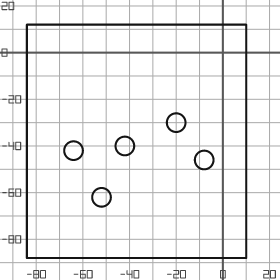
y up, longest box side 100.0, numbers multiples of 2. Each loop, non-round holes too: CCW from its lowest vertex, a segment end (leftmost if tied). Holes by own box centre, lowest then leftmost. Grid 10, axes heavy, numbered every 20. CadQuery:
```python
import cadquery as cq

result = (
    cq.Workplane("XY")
    .moveTo(-84.0, -88.0)
    .lineTo(10.0, -88.0)
    .lineTo(10.0, 12.0)
    .lineTo(-84.0, 12.0)
    .close()
    .moveTo(-52.0, -62.0)
    .circle(4.0)
    .moveTo(-8.0, -46.0)
    .circle(4.0)
    .moveTo(-64.0, -42.0)
    .circle(4.0)
    .moveTo(-42.0, -40.0)
    .circle(4.0)
    .moveTo(-20.0, -30.0)
    .circle(4.0)
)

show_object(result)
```